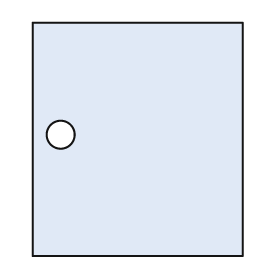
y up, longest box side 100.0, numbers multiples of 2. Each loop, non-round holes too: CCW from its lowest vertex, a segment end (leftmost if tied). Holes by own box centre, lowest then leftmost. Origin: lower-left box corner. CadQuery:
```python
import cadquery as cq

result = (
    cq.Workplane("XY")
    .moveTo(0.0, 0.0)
    .lineTo(90.0, 0.0)
    .lineTo(90.0, 100.0)
    .lineTo(0.0, 100.0)
    .close()
    .moveTo(12.0, 52.0)
    .circle(6.0)
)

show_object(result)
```